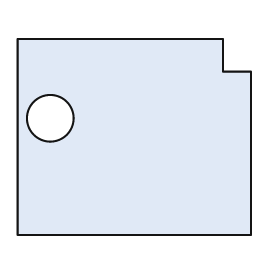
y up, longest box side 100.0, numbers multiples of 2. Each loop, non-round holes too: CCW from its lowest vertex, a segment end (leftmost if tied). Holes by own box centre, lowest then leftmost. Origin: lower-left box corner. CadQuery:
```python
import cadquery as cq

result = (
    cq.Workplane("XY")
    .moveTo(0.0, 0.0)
    .lineTo(100.0, 0.0)
    .lineTo(100.0, 70.0)
    .lineTo(88.0, 70.0)
    .lineTo(88.0, 84.0)
    .lineTo(0.0, 84.0)
    .close()
    .moveTo(14.0, 50.0)
    .circle(10.0)
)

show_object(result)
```